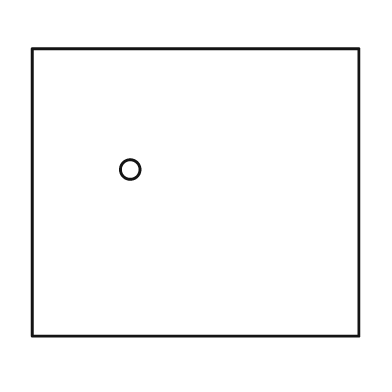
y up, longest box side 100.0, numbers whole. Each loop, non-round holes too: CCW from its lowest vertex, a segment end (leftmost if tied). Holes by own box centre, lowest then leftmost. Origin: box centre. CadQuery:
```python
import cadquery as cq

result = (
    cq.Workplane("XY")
    .moveTo(-50.0, -44.0)
    .lineTo(50.0, -44.0)
    .lineTo(50.0, 44.0)
    .lineTo(-50.0, 44.0)
    .close()
    .moveTo(-20.0, 7.0)
    .circle(3.0)
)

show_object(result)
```